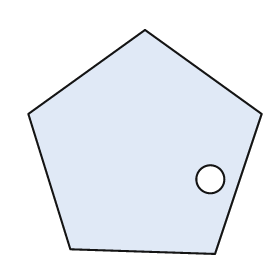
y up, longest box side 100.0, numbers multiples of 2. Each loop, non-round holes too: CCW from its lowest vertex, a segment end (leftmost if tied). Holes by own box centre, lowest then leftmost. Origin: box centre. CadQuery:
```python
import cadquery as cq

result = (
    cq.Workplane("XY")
    .moveTo(30.0, -48.0)
    .lineTo(50.0, 12.0)
    .lineTo(0.0, 48.0)
    .lineTo(-50.0, 12.0)
    .lineTo(-32.0, -46.0)
    .close()
    .moveTo(28.0, -16.0)
    .circle(6.0)
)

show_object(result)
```